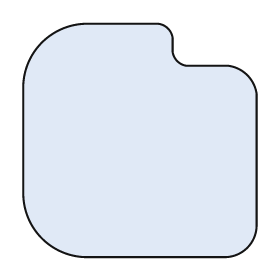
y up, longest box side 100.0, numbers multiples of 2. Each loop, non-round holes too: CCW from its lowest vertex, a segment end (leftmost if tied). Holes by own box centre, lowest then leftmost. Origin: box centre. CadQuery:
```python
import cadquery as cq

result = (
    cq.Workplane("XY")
    .moveTo(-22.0, -50.0)
    .lineTo(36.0, -50.0)
    .threePointArc((46.0, -46.0), (50.0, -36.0))
    .lineTo(50.0, 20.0)
    .threePointArc((46.0, 28.0), (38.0, 32.0))
    .lineTo(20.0, 32.0)
    .threePointArc((16.0, 34.0), (14.0, 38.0))
    .lineTo(14.0, 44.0)
    .threePointArc((12.0, 48.0), (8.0, 50.0))
    .lineTo(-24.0, 50.0)
    .threePointArc((-42.0, 42.0), (-50.0, 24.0))
    .lineTo(-50.0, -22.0)
    .threePointArc((-42.0, -42.0), (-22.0, -50.0))
    .close()
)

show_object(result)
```